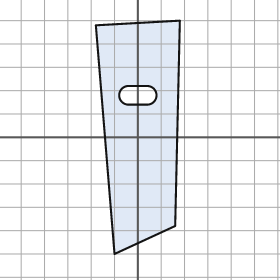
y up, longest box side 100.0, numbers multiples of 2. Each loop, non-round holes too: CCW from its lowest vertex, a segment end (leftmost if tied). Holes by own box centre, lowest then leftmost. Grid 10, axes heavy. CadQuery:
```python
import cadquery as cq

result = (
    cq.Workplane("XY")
    .moveTo(-10.0, -50.0)
    .lineTo(16.0, -38.0)
    .lineTo(18.0, 50.0)
    .lineTo(-18.0, 48.0)
    .close()
    .moveTo(-4.0, 14.0)
    .lineTo(4.0, 14.0)
    .threePointArc((8.0, 18.0), (4.0, 22.0))
    .lineTo(-4.0, 22.0)
    .threePointArc((-8.0, 18.0), (-4.0, 14.0))
    .close()
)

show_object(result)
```